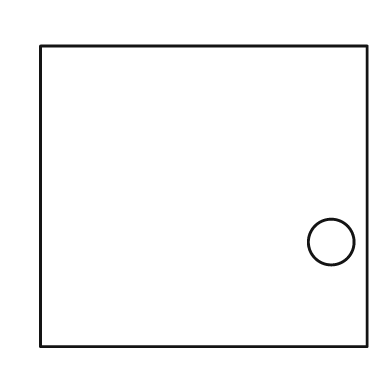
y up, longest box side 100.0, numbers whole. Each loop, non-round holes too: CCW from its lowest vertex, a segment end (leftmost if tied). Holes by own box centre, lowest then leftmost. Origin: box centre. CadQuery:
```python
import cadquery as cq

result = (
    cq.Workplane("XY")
    .moveTo(-50.0, -46.0)
    .lineTo(50.0, -46.0)
    .lineTo(50.0, 46.0)
    .lineTo(-50.0, 46.0)
    .close()
    .moveTo(39.0, -14.0)
    .circle(7.0)
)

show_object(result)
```